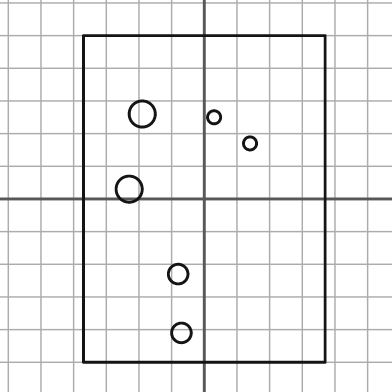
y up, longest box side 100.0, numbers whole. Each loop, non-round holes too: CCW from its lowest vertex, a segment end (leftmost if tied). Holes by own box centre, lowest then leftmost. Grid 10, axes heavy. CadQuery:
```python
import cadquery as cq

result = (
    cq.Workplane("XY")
    .moveTo(-37.0, -50.0)
    .lineTo(37.0, -50.0)
    .lineTo(37.0, 50.0)
    .lineTo(-37.0, 50.0)
    .close()
    .moveTo(-7.0, -41.0)
    .circle(3.0)
    .moveTo(-8.0, -23.0)
    .circle(3.0)
    .moveTo(-23.0, 3.0)
    .circle(4.0)
    .moveTo(14.0, 17.0)
    .circle(2.0)
    .moveTo(3.0, 25.0)
    .circle(2.0)
    .moveTo(-19.0, 26.0)
    .circle(4.0)
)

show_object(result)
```